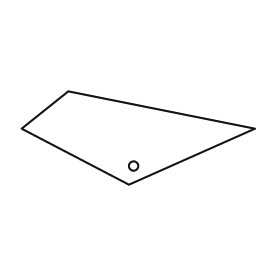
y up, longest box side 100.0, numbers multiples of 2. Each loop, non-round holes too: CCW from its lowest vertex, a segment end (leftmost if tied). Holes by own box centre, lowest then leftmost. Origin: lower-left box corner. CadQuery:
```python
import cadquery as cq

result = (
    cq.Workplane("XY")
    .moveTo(46.0, 0.0)
    .lineTo(100.0, 24.0)
    .lineTo(20.0, 40.0)
    .lineTo(0.0, 24.0)
    .close()
    .moveTo(48.0, 8.0)
    .circle(2.0)
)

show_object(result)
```